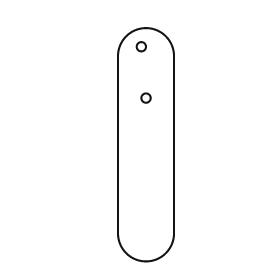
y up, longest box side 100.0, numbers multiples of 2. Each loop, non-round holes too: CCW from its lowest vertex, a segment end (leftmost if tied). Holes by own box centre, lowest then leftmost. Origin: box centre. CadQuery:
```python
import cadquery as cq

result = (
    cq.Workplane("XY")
    .moveTo(-12.0, -38.0)
    .threePointArc((0.0, -50.0), (12.0, -38.0))
    .lineTo(12.0, 38.0)
    .threePointArc((0.0, 50.0), (-12.0, 38.0))
    .close()
    .moveTo(0.0, 20.0)
    .circle(2.0)
    .moveTo(-2.0, 42.0)
    .circle(2.0)
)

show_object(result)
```